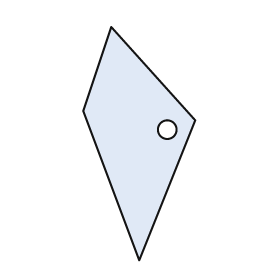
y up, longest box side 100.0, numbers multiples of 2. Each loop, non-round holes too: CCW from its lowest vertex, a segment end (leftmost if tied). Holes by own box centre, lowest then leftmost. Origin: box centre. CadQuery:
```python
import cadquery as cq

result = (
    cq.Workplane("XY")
    .moveTo(0.0, -50.0)
    .lineTo(24.0, 10.0)
    .lineTo(-12.0, 50.0)
    .lineTo(-24.0, 14.0)
    .close()
    .moveTo(12.0, 6.0)
    .circle(4.0)
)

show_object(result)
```